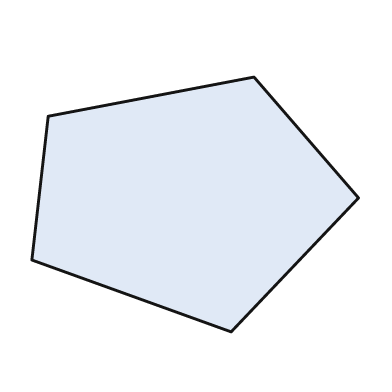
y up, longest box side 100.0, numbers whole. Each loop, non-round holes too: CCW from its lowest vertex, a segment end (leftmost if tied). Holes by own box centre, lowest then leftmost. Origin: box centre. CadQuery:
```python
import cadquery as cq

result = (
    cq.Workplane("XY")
    .moveTo(11.0, -39.0)
    .lineTo(50.0, 2.0)
    .lineTo(18.0, 39.0)
    .lineTo(-45.0, 27.0)
    .lineTo(-50.0, -17.0)
    .close()
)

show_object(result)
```